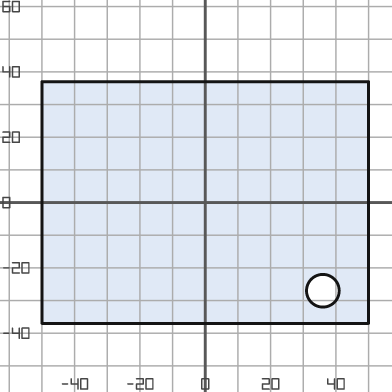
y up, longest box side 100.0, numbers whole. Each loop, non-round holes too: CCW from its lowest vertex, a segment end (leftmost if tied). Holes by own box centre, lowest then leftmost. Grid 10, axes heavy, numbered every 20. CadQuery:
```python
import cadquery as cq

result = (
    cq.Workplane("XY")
    .moveTo(-50.0, -37.0)
    .lineTo(50.0, -37.0)
    .lineTo(50.0, 37.0)
    .lineTo(-50.0, 37.0)
    .close()
    .moveTo(36.0, -27.0)
    .circle(5.0)
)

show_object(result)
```